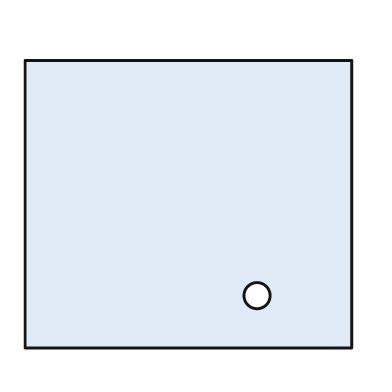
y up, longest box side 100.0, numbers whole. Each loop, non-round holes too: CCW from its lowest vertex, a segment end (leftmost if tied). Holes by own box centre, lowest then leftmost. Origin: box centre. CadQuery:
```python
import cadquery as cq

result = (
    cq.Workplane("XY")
    .moveTo(-50.0, -44.0)
    .lineTo(50.0, -44.0)
    .lineTo(50.0, 44.0)
    .lineTo(-50.0, 44.0)
    .close()
    .moveTo(21.0, -28.0)
    .circle(4.0)
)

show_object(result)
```